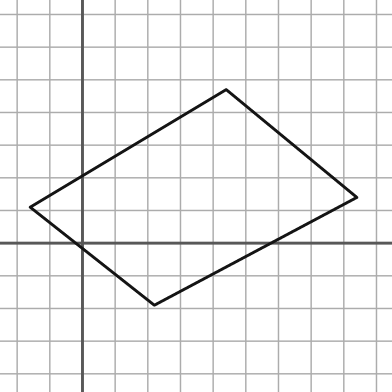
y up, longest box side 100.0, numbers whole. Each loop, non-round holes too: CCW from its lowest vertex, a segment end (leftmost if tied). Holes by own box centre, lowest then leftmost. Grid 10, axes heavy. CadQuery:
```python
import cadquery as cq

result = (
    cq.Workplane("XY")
    .moveTo(22.0, -19.0)
    .lineTo(84.0, 14.0)
    .lineTo(44.0, 47.0)
    .lineTo(-16.0, 11.0)
    .close()
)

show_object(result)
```